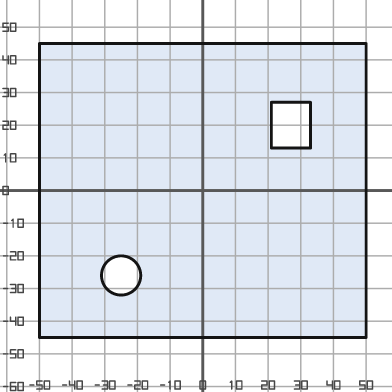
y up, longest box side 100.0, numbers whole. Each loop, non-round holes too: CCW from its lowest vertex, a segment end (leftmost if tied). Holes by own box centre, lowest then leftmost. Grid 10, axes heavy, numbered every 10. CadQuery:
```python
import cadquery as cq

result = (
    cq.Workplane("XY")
    .moveTo(-50.0, -45.0)
    .lineTo(50.0, -45.0)
    .lineTo(50.0, 45.0)
    .lineTo(-50.0, 45.0)
    .close()
    .moveTo(-25.0, -26.0)
    .circle(6.0)
    .moveTo(21.0, 13.0)
    .lineTo(33.0, 13.0)
    .lineTo(33.0, 27.0)
    .lineTo(21.0, 27.0)
    .close()
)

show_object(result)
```